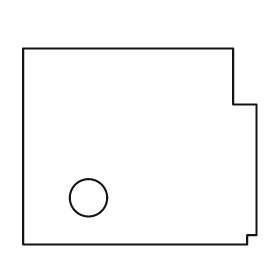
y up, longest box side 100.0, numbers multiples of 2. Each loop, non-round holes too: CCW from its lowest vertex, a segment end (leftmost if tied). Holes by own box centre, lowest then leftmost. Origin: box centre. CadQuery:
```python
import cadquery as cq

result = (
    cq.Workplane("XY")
    .moveTo(-50.0, -42.0)
    .lineTo(46.0, -42.0)
    .lineTo(46.0, -38.0)
    .lineTo(50.0, -38.0)
    .lineTo(50.0, 18.0)
    .lineTo(40.0, 18.0)
    .lineTo(40.0, 42.0)
    .lineTo(-50.0, 42.0)
    .close()
    .moveTo(-22.0, -22.0)
    .circle(8.0)
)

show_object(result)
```